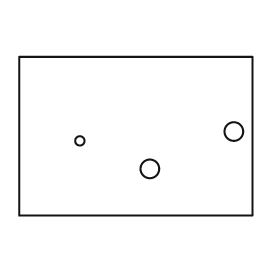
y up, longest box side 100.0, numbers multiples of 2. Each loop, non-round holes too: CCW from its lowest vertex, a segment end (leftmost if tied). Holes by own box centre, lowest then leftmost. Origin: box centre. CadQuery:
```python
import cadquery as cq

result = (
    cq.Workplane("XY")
    .moveTo(-50.0, -34.0)
    .lineTo(50.0, -34.0)
    .lineTo(50.0, 34.0)
    .lineTo(-50.0, 34.0)
    .close()
    .moveTo(6.0, -14.0)
    .circle(4.0)
    .moveTo(-24.0, -2.0)
    .circle(2.0)
    .moveTo(42.0, 2.0)
    .circle(4.0)
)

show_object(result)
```